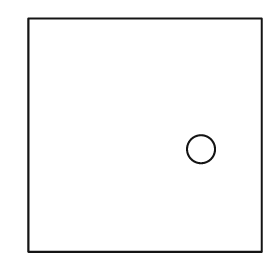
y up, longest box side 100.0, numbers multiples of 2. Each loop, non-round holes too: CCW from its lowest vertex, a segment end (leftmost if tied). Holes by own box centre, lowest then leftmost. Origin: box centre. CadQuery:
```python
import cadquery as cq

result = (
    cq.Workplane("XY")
    .moveTo(-50.0, -50.0)
    .lineTo(50.0, -50.0)
    .lineTo(50.0, 50.0)
    .lineTo(-50.0, 50.0)
    .close()
    .moveTo(24.0, -6.0)
    .circle(6.0)
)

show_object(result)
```